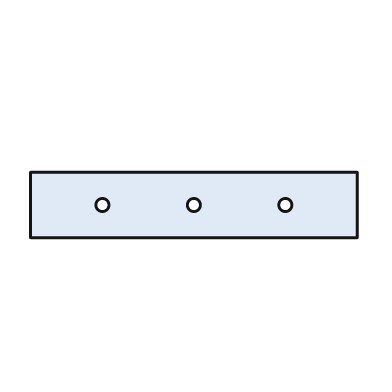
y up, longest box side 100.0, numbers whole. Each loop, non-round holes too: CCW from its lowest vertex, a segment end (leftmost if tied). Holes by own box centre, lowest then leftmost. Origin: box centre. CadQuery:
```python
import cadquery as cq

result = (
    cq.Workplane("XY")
    .moveTo(-50.0, -10.0)
    .lineTo(50.0, -10.0)
    .lineTo(50.0, 10.0)
    .lineTo(-50.0, 10.0)
    .close()
    .moveTo(-28.0, 0.0)
    .circle(2.0)
    .moveTo(0.0, 0.0)
    .circle(2.0)
    .moveTo(28.0, 0.0)
    .circle(2.0)
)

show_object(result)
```